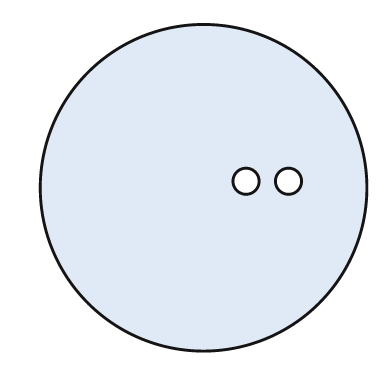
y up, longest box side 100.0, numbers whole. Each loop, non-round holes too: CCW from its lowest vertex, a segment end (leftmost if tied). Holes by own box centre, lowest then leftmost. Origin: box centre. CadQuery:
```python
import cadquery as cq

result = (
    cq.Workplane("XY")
    .moveTo(0.0, 0.0)
    .circle(50.0)
    .moveTo(13.0, 2.0)
    .circle(4.0)
    .moveTo(26.0, 2.0)
    .circle(4.0)
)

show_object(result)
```